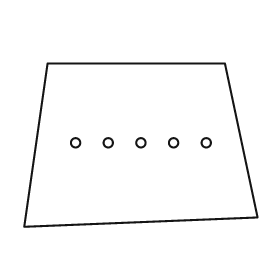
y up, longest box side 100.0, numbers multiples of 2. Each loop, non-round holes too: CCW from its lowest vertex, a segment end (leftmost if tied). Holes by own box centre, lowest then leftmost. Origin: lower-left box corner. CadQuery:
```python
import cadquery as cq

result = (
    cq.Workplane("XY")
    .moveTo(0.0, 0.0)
    .lineTo(100.0, 4.0)
    .lineTo(86.0, 70.0)
    .lineTo(10.0, 70.0)
    .close()
    .moveTo(22.0, 36.0)
    .circle(2.0)
    .moveTo(36.0, 36.0)
    .circle(2.0)
    .moveTo(50.0, 36.0)
    .circle(2.0)
    .moveTo(64.0, 36.0)
    .circle(2.0)
    .moveTo(78.0, 36.0)
    .circle(2.0)
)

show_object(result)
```